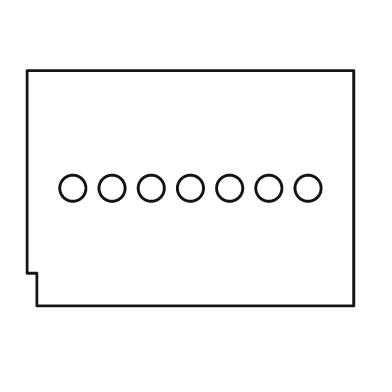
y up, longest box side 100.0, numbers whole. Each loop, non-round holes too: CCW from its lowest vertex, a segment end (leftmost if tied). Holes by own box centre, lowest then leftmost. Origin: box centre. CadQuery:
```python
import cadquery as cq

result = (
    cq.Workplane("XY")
    .moveTo(-47.0, -36.0)
    .lineTo(50.0, -36.0)
    .lineTo(50.0, 36.0)
    .lineTo(-50.0, 36.0)
    .lineTo(-50.0, -26.0)
    .lineTo(-47.0, -26.0)
    .close()
    .moveTo(-36.0, 0.0)
    .circle(4.0)
    .moveTo(-24.0, 0.0)
    .circle(4.0)
    .moveTo(-12.0, 0.0)
    .circle(4.0)
    .moveTo(0.0, 0.0)
    .circle(4.0)
    .moveTo(12.0, 0.0)
    .circle(4.0)
    .moveTo(24.0, 0.0)
    .circle(4.0)
    .moveTo(36.0, 0.0)
    .circle(4.0)
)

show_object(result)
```